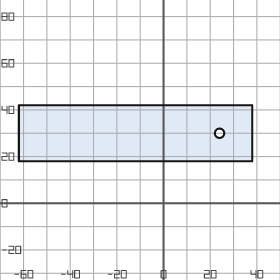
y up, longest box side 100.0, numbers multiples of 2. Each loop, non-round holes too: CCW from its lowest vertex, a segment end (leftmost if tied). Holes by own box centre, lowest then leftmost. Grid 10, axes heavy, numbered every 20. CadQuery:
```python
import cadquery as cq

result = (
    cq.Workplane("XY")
    .moveTo(-62.0, 18.0)
    .lineTo(38.0, 18.0)
    .lineTo(38.0, 42.0)
    .lineTo(-62.0, 42.0)
    .close()
    .moveTo(24.0, 30.0)
    .circle(2.0)
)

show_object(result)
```